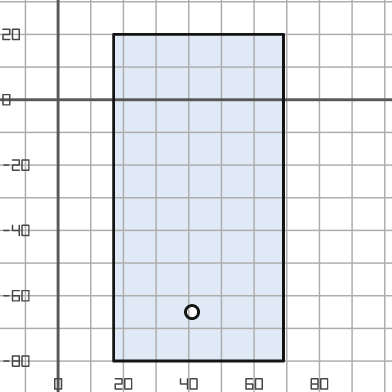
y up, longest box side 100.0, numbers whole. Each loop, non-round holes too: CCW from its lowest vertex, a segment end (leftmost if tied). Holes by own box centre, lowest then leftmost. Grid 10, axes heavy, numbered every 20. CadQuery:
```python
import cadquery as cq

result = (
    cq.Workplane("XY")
    .moveTo(17.0, -80.0)
    .lineTo(69.0, -80.0)
    .lineTo(69.0, 20.0)
    .lineTo(17.0, 20.0)
    .close()
    .moveTo(41.0, -65.0)
    .circle(2.0)
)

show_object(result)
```